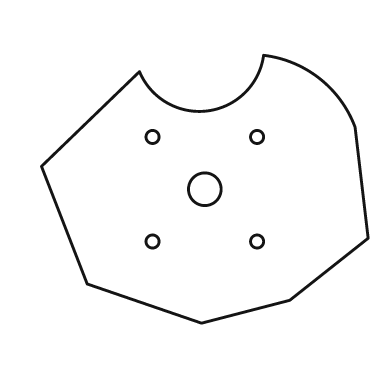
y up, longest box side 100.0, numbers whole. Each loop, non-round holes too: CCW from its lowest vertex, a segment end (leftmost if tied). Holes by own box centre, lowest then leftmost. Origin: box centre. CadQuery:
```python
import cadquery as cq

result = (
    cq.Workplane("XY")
    .moveTo(-1.0, -41.0)
    .lineTo(26.0, -34.0)
    .lineTo(50.0, -15.0)
    .lineTo(46.0, 19.0)
    .threePointArc((35.0, 34.0), (18.0, 41.0))
    .threePointArc((1.0, 24.0), (-20.0, 36.0))
    .lineTo(-50.0, 7.0)
    .lineTo(-36.0, -29.0)
    .close()
    .moveTo(-16.0, -16.0)
    .circle(2.0)
    .moveTo(16.0, -16.0)
    .circle(2.0)
    .moveTo(0.0, 0.0)
    .circle(5.0)
    .moveTo(-16.0, 16.0)
    .circle(2.0)
    .moveTo(16.0, 16.0)
    .circle(2.0)
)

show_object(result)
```